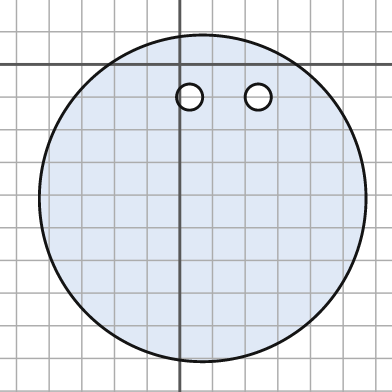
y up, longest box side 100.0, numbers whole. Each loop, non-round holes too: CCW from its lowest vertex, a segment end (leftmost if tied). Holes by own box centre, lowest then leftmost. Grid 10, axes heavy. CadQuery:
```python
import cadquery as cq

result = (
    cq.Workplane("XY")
    .moveTo(7.0, -41.0)
    .circle(50.0)
    .moveTo(3.0, -10.0)
    .circle(4.0)
    .moveTo(24.0, -10.0)
    .circle(4.0)
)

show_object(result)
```